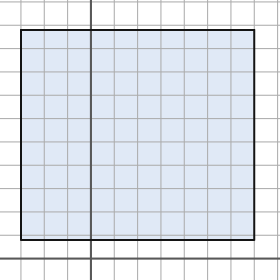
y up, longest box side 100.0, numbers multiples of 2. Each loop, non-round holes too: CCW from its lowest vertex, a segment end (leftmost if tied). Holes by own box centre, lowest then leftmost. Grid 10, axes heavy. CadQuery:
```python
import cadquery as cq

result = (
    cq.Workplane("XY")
    .moveTo(-30.0, 8.0)
    .lineTo(70.0, 8.0)
    .lineTo(70.0, 98.0)
    .lineTo(-30.0, 98.0)
    .close()
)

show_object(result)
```